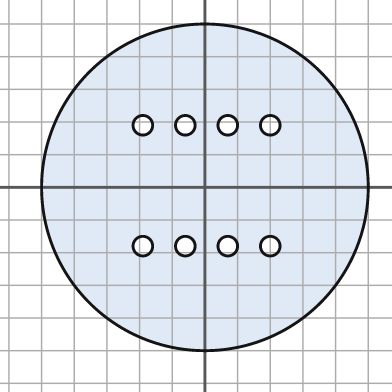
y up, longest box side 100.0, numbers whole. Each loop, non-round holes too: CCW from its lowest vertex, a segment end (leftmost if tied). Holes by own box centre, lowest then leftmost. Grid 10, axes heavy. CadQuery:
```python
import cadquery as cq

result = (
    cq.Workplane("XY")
    .moveTo(0.0, 0.0)
    .circle(50.0)
    .moveTo(-19.0, -18.0)
    .circle(3.0)
    .moveTo(-6.0, -18.0)
    .circle(3.0)
    .moveTo(7.0, -18.0)
    .circle(3.0)
    .moveTo(20.0, -18.0)
    .circle(3.0)
    .moveTo(-19.0, 19.0)
    .circle(3.0)
    .moveTo(-6.0, 19.0)
    .circle(3.0)
    .moveTo(7.0, 19.0)
    .circle(3.0)
    .moveTo(20.0, 19.0)
    .circle(3.0)
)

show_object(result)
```